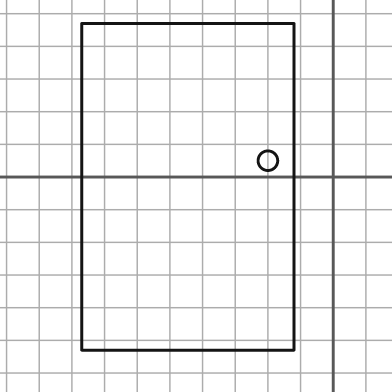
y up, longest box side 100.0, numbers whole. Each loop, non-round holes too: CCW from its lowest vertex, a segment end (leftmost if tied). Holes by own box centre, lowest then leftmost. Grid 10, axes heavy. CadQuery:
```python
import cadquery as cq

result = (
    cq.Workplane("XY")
    .moveTo(-77.0, -53.0)
    .lineTo(-12.0, -53.0)
    .lineTo(-12.0, 47.0)
    .lineTo(-77.0, 47.0)
    .close()
    .moveTo(-20.0, 5.0)
    .circle(3.0)
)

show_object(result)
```